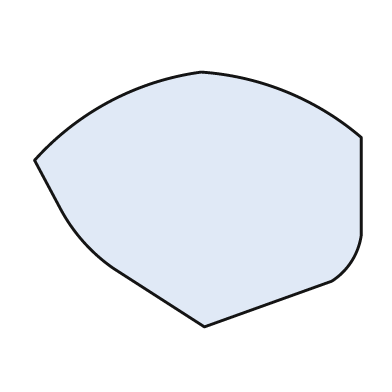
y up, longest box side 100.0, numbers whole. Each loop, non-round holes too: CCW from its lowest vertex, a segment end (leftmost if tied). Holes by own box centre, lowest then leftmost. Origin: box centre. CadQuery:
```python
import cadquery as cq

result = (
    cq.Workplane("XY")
    .moveTo(2.0, -39.0)
    .lineTo(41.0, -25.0)
    .threePointArc((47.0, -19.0), (50.0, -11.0))
    .lineTo(50.0, 19.0)
    .threePointArc((27.0, 33.0), (1.0, 39.0))
    .threePointArc((-27.0, 30.0), (-50.0, 12.0))
    .lineTo(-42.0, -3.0)
    .threePointArc((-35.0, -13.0), (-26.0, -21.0))
    .close()
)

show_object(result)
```